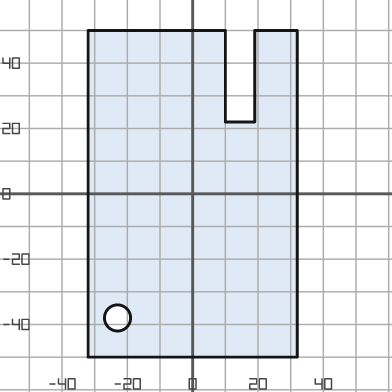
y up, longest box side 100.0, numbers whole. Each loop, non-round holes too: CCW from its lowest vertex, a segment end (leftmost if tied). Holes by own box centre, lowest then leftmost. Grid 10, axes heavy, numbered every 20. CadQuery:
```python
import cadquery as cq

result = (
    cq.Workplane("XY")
    .moveTo(-32.0, -50.0)
    .lineTo(32.0, -50.0)
    .lineTo(32.0, 50.0)
    .lineTo(19.0, 50.0)
    .lineTo(19.0, 22.0)
    .lineTo(10.0, 22.0)
    .lineTo(10.0, 50.0)
    .lineTo(-32.0, 50.0)
    .close()
    .moveTo(-23.0, -38.0)
    .circle(4.0)
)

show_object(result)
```